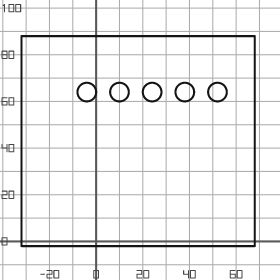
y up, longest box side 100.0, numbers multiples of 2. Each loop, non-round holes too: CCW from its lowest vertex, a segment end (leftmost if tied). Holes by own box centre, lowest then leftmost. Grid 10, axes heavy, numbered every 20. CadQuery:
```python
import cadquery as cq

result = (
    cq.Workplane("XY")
    .moveTo(-32.0, -2.0)
    .lineTo(68.0, -2.0)
    .lineTo(68.0, 88.0)
    .lineTo(-32.0, 88.0)
    .close()
    .moveTo(-4.0, 64.0)
    .circle(4.0)
    .moveTo(10.0, 64.0)
    .circle(4.0)
    .moveTo(24.0, 64.0)
    .circle(4.0)
    .moveTo(38.0, 64.0)
    .circle(4.0)
    .moveTo(52.0, 64.0)
    .circle(4.0)
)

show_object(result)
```